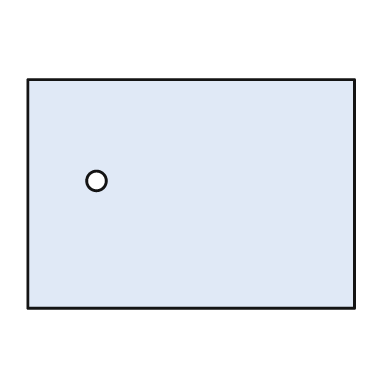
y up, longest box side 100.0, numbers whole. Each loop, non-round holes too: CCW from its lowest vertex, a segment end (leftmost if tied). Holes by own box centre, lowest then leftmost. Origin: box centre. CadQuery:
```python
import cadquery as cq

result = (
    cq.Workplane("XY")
    .moveTo(-50.0, -35.0)
    .lineTo(50.0, -35.0)
    .lineTo(50.0, 35.0)
    .lineTo(-50.0, 35.0)
    .close()
    .moveTo(-29.0, 4.0)
    .circle(3.0)
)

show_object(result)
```